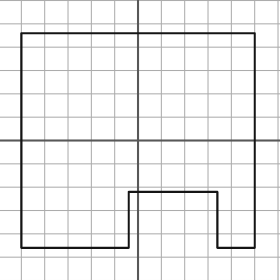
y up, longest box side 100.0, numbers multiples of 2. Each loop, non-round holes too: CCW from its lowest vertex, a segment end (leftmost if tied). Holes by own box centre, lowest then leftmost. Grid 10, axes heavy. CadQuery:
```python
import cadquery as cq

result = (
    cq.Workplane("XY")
    .moveTo(-50.0, -46.0)
    .lineTo(-4.0, -46.0)
    .lineTo(-4.0, -22.0)
    .lineTo(34.0, -22.0)
    .lineTo(34.0, -46.0)
    .lineTo(50.0, -46.0)
    .lineTo(50.0, 46.0)
    .lineTo(-50.0, 46.0)
    .close()
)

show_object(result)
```